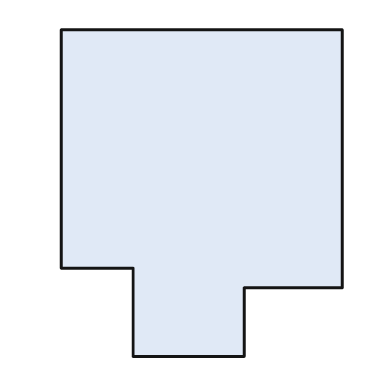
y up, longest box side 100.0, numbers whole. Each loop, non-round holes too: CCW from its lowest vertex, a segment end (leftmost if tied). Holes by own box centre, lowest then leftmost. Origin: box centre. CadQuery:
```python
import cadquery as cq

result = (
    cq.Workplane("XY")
    .moveTo(-21.0, -50.0)
    .lineTo(13.0, -50.0)
    .lineTo(13.0, -29.0)
    .lineTo(43.0, -29.0)
    .lineTo(43.0, 50.0)
    .lineTo(-43.0, 50.0)
    .lineTo(-43.0, -23.0)
    .lineTo(-21.0, -23.0)
    .close()
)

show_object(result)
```